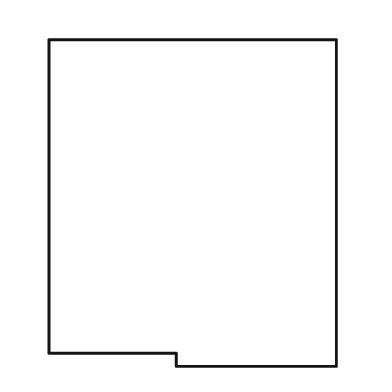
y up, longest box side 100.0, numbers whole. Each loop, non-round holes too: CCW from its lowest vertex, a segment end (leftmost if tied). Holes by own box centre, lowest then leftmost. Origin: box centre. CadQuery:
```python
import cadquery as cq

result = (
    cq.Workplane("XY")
    .moveTo(-5.0, -50.0)
    .lineTo(44.0, -50.0)
    .lineTo(44.0, 50.0)
    .lineTo(-44.0, 50.0)
    .lineTo(-44.0, -46.0)
    .lineTo(-5.0, -46.0)
    .close()
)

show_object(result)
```